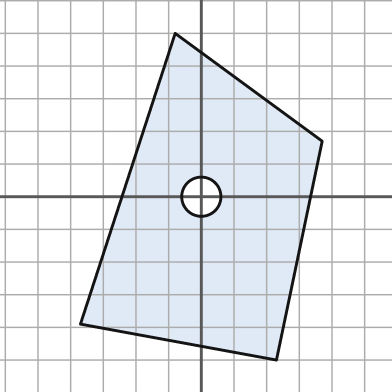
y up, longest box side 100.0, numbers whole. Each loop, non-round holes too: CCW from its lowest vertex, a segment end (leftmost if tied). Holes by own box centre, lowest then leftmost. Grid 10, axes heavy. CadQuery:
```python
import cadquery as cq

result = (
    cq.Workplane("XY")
    .moveTo(23.0, -50.0)
    .lineTo(37.0, 17.0)
    .lineTo(-8.0, 50.0)
    .lineTo(-37.0, -39.0)
    .close()
    .moveTo(0.0, 0.0)
    .circle(6.0)
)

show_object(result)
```